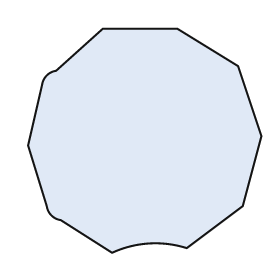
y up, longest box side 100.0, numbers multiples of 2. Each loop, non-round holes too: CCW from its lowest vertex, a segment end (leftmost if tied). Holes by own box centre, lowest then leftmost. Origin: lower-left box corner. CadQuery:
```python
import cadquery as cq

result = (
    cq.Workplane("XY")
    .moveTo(36.0, 0.0)
    .threePointArc((52.0, 4.0), (68.0, 2.0))
    .lineTo(92.0, 20.0)
    .lineTo(100.0, 50.0)
    .lineTo(90.0, 80.0)
    .lineTo(64.0, 96.0)
    .lineTo(32.0, 96.0)
    .lineTo(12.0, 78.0)
    .threePointArc((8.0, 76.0), (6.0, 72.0))
    .lineTo(0.0, 46.0)
    .lineTo(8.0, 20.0)
    .threePointArc((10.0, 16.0), (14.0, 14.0))
    .close()
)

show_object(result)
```